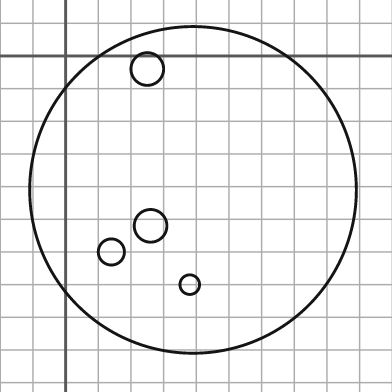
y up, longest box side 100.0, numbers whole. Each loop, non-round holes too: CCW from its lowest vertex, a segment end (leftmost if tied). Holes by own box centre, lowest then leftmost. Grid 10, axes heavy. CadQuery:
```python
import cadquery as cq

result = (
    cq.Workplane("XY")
    .moveTo(39.0, -41.0)
    .circle(50.0)
    .moveTo(38.0, -70.0)
    .circle(3.0)
    .moveTo(14.0, -60.0)
    .circle(4.0)
    .moveTo(26.0, -52.0)
    .circle(5.0)
    .moveTo(25.0, -4.0)
    .circle(5.0)
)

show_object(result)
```